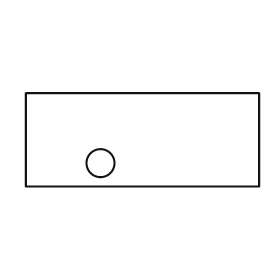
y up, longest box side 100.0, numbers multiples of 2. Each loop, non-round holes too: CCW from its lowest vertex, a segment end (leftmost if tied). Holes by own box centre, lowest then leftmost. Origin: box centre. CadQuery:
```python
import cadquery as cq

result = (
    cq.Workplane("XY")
    .moveTo(-50.0, -20.0)
    .lineTo(50.0, -20.0)
    .lineTo(50.0, 20.0)
    .lineTo(-50.0, 20.0)
    .close()
    .moveTo(-18.0, -10.0)
    .circle(6.0)
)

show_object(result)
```